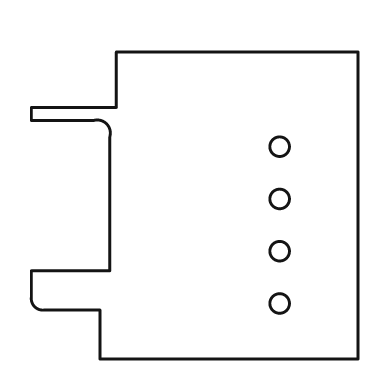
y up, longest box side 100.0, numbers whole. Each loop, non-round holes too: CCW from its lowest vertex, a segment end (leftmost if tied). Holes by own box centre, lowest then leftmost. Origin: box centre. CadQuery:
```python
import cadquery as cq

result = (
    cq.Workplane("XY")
    .moveTo(-29.0, -47.0)
    .lineTo(50.0, -47.0)
    .lineTo(50.0, 47.0)
    .lineTo(-24.0, 47.0)
    .lineTo(-24.0, 30.0)
    .lineTo(-50.0, 30.0)
    .lineTo(-50.0, 26.0)
    .lineTo(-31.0, 26.0)
    .threePointArc((-27.0, 25.0), (-26.0, 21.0))
    .lineTo(-26.0, -20.0)
    .lineTo(-50.0, -20.0)
    .lineTo(-50.0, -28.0)
    .threePointArc((-49.0, -31.0), (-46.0, -32.0))
    .lineTo(-29.0, -32.0)
    .close()
    .moveTo(26.0, -30.0)
    .circle(3.0)
    .moveTo(26.0, -14.0)
    .circle(3.0)
    .moveTo(26.0, 2.0)
    .circle(3.0)
    .moveTo(26.0, 18.0)
    .circle(3.0)
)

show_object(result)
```